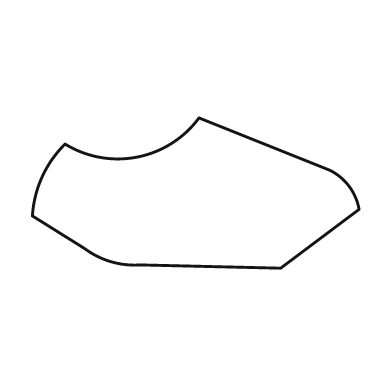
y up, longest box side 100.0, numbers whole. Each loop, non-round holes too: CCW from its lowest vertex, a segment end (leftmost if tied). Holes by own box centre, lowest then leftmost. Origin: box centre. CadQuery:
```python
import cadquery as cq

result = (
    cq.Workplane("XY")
    .moveTo(26.0, -23.0)
    .lineTo(50.0, -5.0)
    .threePointArc((47.0, 2.0), (41.0, 7.0))
    .lineTo(1.0, 23.0)
    .threePointArc((-18.0, 11.0), (-40.0, 15.0))
    .threePointArc((-47.0, 5.0), (-50.0, -7.0))
    .lineTo(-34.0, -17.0)
    .threePointArc((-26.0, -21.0), (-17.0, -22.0))
    .close()
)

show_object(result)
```